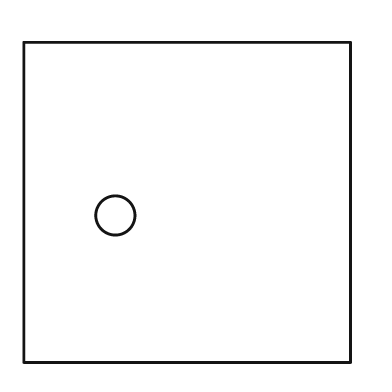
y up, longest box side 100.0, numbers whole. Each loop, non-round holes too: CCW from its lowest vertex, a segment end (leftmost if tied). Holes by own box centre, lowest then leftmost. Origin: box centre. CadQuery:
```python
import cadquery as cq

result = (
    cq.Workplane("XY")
    .moveTo(-50.0, -49.0)
    .lineTo(50.0, -49.0)
    .lineTo(50.0, 49.0)
    .lineTo(-50.0, 49.0)
    .close()
    .moveTo(-22.0, -4.0)
    .circle(6.0)
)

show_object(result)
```